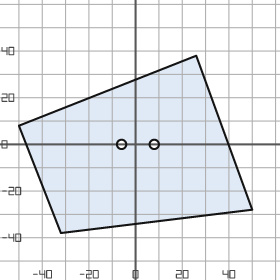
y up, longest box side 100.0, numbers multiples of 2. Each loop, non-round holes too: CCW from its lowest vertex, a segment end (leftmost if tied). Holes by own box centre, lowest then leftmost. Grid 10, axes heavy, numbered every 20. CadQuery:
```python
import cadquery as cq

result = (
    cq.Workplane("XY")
    .moveTo(-32.0, -38.0)
    .lineTo(50.0, -28.0)
    .lineTo(26.0, 38.0)
    .lineTo(-50.0, 8.0)
    .close()
    .moveTo(-6.0, 0.0)
    .circle(2.0)
    .moveTo(8.0, 0.0)
    .circle(2.0)
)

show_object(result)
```